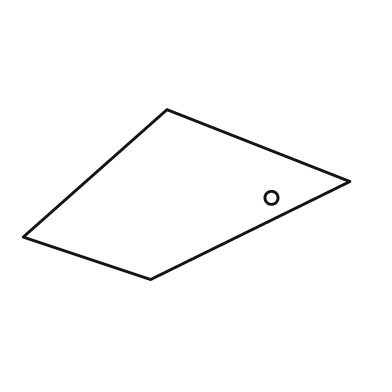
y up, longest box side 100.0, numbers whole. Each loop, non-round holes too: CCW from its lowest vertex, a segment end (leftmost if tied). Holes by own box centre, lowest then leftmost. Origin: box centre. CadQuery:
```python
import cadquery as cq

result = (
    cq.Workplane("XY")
    .moveTo(-11.0, -26.0)
    .lineTo(50.0, 4.0)
    .lineTo(-6.0, 26.0)
    .lineTo(-50.0, -13.0)
    .close()
    .moveTo(26.0, -1.0)
    .circle(2.0)
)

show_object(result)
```